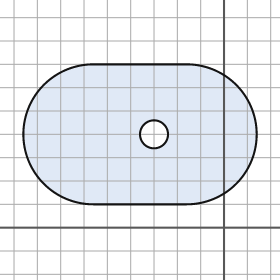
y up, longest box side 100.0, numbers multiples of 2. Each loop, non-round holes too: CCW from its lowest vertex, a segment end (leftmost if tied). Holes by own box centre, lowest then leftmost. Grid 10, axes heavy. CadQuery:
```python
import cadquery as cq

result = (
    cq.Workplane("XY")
    .moveTo(-56.0, 10.0)
    .lineTo(-16.0, 10.0)
    .threePointArc((14.0, 40.0), (-16.0, 70.0))
    .lineTo(-56.0, 70.0)
    .threePointArc((-86.0, 40.0), (-56.0, 10.0))
    .close()
    .moveTo(-30.0, 40.0)
    .circle(6.0)
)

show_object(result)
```